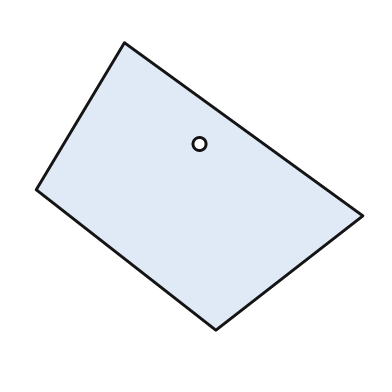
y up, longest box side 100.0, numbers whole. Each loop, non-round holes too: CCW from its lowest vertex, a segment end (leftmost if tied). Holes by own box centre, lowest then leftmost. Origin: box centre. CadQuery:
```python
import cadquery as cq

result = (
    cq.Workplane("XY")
    .moveTo(5.0, -44.0)
    .lineTo(50.0, -9.0)
    .lineTo(-23.0, 44.0)
    .lineTo(-50.0, -1.0)
    .close()
    .moveTo(0.0, 13.0)
    .circle(2.0)
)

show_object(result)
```